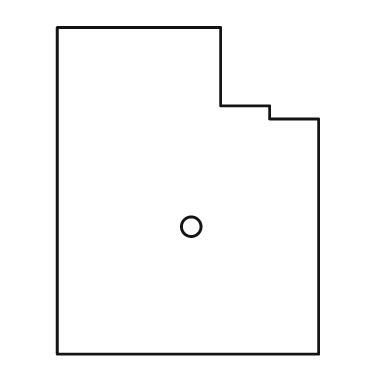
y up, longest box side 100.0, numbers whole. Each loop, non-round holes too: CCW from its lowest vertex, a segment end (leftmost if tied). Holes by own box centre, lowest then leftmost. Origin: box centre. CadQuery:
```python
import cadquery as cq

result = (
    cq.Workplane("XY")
    .moveTo(-40.0, -50.0)
    .lineTo(40.0, -50.0)
    .lineTo(40.0, 22.0)
    .lineTo(25.0, 22.0)
    .lineTo(25.0, 26.0)
    .lineTo(10.0, 26.0)
    .lineTo(10.0, 50.0)
    .lineTo(-40.0, 50.0)
    .close()
    .moveTo(1.0, -11.0)
    .circle(3.0)
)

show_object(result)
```